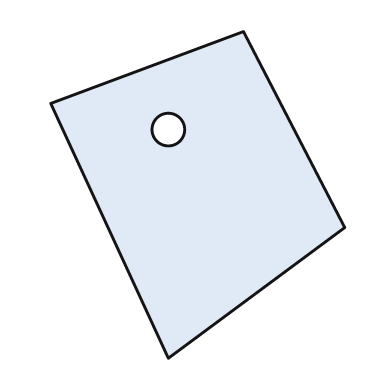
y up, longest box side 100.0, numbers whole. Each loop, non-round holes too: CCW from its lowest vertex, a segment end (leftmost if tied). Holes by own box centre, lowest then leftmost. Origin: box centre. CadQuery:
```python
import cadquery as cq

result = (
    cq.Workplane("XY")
    .moveTo(-9.0, -50.0)
    .lineTo(45.0, -10.0)
    .lineTo(14.0, 50.0)
    .lineTo(-45.0, 28.0)
    .close()
    .moveTo(-9.0, 20.0)
    .circle(5.0)
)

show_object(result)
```